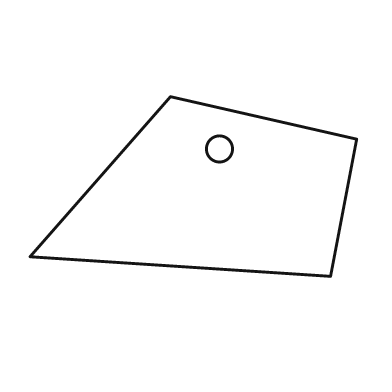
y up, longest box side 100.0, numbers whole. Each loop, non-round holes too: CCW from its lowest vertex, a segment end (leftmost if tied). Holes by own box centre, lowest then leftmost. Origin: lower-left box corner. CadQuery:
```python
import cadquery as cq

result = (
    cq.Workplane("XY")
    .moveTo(92.0, 0.0)
    .lineTo(100.0, 42.0)
    .lineTo(43.0, 55.0)
    .lineTo(0.0, 6.0)
    .close()
    .moveTo(58.0, 39.0)
    .circle(4.0)
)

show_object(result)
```